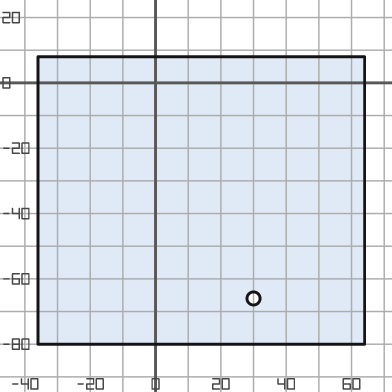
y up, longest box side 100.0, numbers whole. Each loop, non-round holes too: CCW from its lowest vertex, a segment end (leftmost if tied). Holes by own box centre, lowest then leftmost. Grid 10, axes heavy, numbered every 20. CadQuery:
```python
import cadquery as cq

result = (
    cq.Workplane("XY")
    .moveTo(-36.0, -80.0)
    .lineTo(64.0, -80.0)
    .lineTo(64.0, 8.0)
    .lineTo(-36.0, 8.0)
    .close()
    .moveTo(30.0, -66.0)
    .circle(2.0)
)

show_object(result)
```